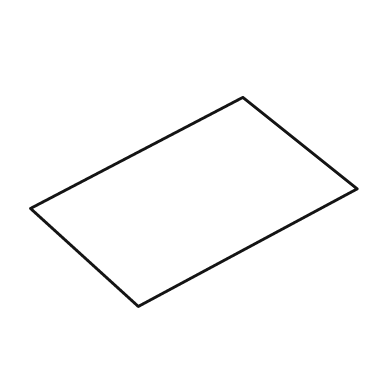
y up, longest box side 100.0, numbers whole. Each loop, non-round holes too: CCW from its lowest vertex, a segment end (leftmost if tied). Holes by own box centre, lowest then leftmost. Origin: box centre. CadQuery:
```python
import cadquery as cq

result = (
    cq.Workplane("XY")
    .moveTo(-17.0, -32.0)
    .lineTo(50.0, 4.0)
    .lineTo(15.0, 32.0)
    .lineTo(-50.0, -2.0)
    .close()
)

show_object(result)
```